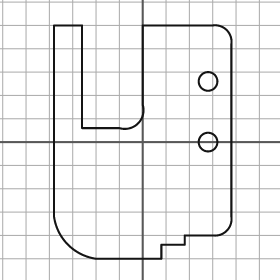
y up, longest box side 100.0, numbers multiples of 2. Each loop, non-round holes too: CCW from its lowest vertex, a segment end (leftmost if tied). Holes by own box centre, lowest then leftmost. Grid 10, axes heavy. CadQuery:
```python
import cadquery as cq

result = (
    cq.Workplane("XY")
    .moveTo(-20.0, -50.0)
    .lineTo(8.0, -50.0)
    .lineTo(8.0, -44.0)
    .lineTo(18.0, -44.0)
    .lineTo(18.0, -40.0)
    .lineTo(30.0, -40.0)
    .threePointArc((36.0, -38.0), (38.0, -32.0))
    .lineTo(38.0, 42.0)
    .threePointArc((36.0, 48.0), (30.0, 50.0))
    .lineTo(0.0, 50.0)
    .lineTo(0.0, 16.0)
    .threePointArc((-2.0, 8.0), (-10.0, 6.0))
    .lineTo(-26.0, 6.0)
    .lineTo(-26.0, 50.0)
    .lineTo(-38.0, 50.0)
    .lineTo(-38.0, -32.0)
    .threePointArc((-32.0, -44.0), (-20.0, -50.0))
    .close()
    .moveTo(28.0, 0.0)
    .circle(4.0)
    .moveTo(28.0, 26.0)
    .circle(4.0)
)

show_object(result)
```